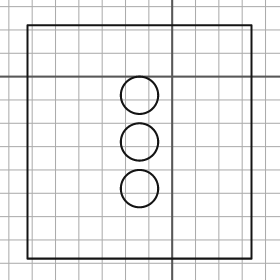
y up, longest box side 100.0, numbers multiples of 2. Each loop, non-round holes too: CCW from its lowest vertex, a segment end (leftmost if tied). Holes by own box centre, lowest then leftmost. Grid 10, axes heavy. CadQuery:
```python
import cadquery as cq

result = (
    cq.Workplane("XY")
    .moveTo(-62.0, -78.0)
    .lineTo(34.0, -78.0)
    .lineTo(34.0, 22.0)
    .lineTo(-62.0, 22.0)
    .close()
    .moveTo(-14.0, -48.0)
    .circle(8.0)
    .moveTo(-14.0, -28.0)
    .circle(8.0)
    .moveTo(-14.0, -8.0)
    .circle(8.0)
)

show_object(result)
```